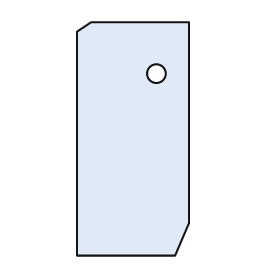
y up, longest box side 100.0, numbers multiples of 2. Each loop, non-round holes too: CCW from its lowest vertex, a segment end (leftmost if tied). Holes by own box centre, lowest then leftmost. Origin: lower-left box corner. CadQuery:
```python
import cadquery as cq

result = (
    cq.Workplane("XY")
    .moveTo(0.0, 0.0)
    .lineTo(42.0, 0.0)
    .lineTo(48.0, 14.0)
    .lineTo(48.0, 100.0)
    .lineTo(6.0, 100.0)
    .lineTo(0.0, 96.0)
    .close()
    .moveTo(34.0, 78.0)
    .circle(4.0)
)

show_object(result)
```